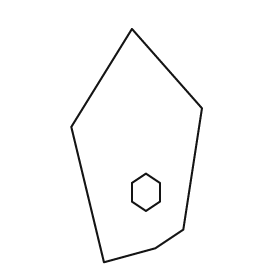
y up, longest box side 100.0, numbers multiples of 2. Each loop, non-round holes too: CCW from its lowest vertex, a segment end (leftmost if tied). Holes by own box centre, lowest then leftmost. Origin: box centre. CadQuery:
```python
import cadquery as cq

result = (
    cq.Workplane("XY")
    .moveTo(-14.0, -50.0)
    .lineTo(8.0, -44.0)
    .lineTo(20.0, -36.0)
    .lineTo(28.0, 16.0)
    .lineTo(-2.0, 50.0)
    .lineTo(-28.0, 8.0)
    .close()
    .moveTo(4.0, -28.0)
    .lineTo(10.0, -24.0)
    .lineTo(10.0, -16.0)
    .lineTo(4.0, -12.0)
    .lineTo(-2.0, -16.0)
    .lineTo(-2.0, -24.0)
    .close()
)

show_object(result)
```